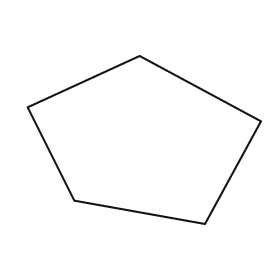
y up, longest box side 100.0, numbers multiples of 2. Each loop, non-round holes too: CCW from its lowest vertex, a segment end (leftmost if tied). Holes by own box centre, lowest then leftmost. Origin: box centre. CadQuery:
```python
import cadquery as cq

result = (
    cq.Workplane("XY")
    .moveTo(26.0, -36.0)
    .lineTo(50.0, 8.0)
    .lineTo(-2.0, 36.0)
    .lineTo(-50.0, 14.0)
    .lineTo(-30.0, -26.0)
    .close()
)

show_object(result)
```